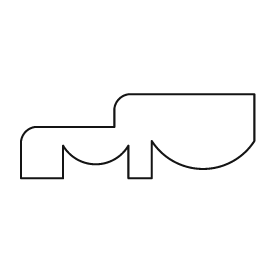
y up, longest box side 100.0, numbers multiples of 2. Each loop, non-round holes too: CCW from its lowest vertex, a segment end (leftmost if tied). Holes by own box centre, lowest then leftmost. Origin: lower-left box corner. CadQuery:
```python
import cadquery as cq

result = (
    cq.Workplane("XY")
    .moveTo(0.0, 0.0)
    .lineTo(18.0, 0.0)
    .lineTo(18.0, 14.0)
    .threePointArc((32.0, 6.0), (46.0, 14.0))
    .lineTo(46.0, 0.0)
    .lineTo(56.0, 0.0)
    .lineTo(56.0, 16.0)
    .threePointArc((78.0, 4.0), (100.0, 16.0))
    .lineTo(100.0, 36.0)
    .lineTo(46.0, 36.0)
    .threePointArc((42.0, 34.0), (40.0, 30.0))
    .lineTo(40.0, 22.0)
    .lineTo(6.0, 22.0)
    .threePointArc((2.0, 20.0), (0.0, 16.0))
    .close()
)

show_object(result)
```